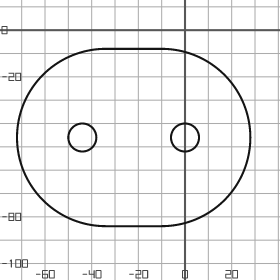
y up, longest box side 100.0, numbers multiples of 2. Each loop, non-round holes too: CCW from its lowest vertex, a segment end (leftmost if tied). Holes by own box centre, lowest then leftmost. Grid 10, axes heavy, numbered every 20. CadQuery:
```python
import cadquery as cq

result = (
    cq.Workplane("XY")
    .moveTo(-34.0, -84.0)
    .lineTo(-10.0, -84.0)
    .threePointArc((28.0, -46.0), (-10.0, -8.0))
    .lineTo(-34.0, -8.0)
    .threePointArc((-72.0, -46.0), (-34.0, -84.0))
    .close()
    .moveTo(-44.0, -46.0)
    .circle(6.0)
    .moveTo(0.0, -46.0)
    .circle(6.0)
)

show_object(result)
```